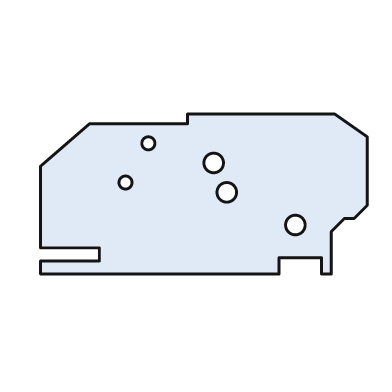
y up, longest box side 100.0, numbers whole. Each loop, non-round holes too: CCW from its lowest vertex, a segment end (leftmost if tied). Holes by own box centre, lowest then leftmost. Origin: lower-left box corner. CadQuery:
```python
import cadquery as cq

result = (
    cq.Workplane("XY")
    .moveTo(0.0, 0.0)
    .lineTo(73.0, 0.0)
    .lineTo(73.0, 5.0)
    .lineTo(86.0, 5.0)
    .lineTo(86.0, 0.0)
    .lineTo(89.0, 0.0)
    .lineTo(89.0, 13.0)
    .lineTo(93.0, 17.0)
    .lineTo(96.0, 17.0)
    .lineTo(100.0, 21.0)
    .lineTo(100.0, 42.0)
    .lineTo(90.0, 49.0)
    .lineTo(45.0, 49.0)
    .lineTo(45.0, 46.0)
    .lineTo(15.0, 46.0)
    .lineTo(0.0, 33.0)
    .lineTo(0.0, 8.0)
    .lineTo(18.0, 8.0)
    .lineTo(18.0, 4.0)
    .lineTo(0.0, 4.0)
    .close()
    .moveTo(78.0, 15.0)
    .circle(3.0)
    .moveTo(57.0, 25.0)
    .circle(3.0)
    .moveTo(26.0, 28.0)
    .circle(2.0)
    .moveTo(53.0, 34.0)
    .circle(3.0)
    .moveTo(33.0, 40.0)
    .circle(2.0)
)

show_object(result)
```